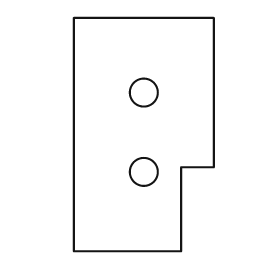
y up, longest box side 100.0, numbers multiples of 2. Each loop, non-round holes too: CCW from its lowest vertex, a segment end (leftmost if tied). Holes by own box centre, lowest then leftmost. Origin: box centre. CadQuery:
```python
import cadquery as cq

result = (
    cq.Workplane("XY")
    .moveTo(-30.0, -50.0)
    .lineTo(16.0, -50.0)
    .lineTo(16.0, -14.0)
    .lineTo(30.0, -14.0)
    .lineTo(30.0, 50.0)
    .lineTo(-30.0, 50.0)
    .close()
    .moveTo(0.0, -16.0)
    .circle(6.0)
    .moveTo(0.0, 18.0)
    .circle(6.0)
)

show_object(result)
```